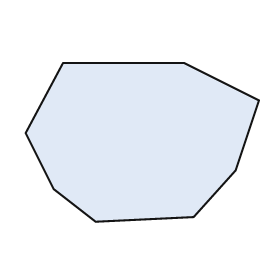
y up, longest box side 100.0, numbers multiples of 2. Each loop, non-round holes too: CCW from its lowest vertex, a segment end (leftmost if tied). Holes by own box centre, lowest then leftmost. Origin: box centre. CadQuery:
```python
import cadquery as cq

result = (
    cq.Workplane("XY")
    .moveTo(-20.0, -34.0)
    .lineTo(22.0, -32.0)
    .lineTo(40.0, -12.0)
    .lineTo(50.0, 18.0)
    .lineTo(18.0, 34.0)
    .lineTo(-34.0, 34.0)
    .lineTo(-50.0, 4.0)
    .lineTo(-38.0, -20.0)
    .close()
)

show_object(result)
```